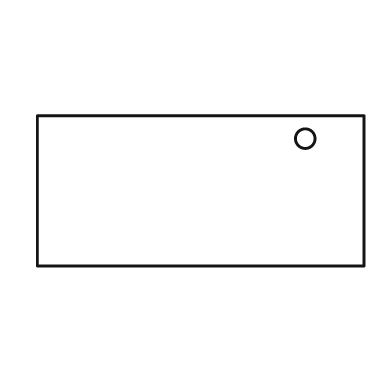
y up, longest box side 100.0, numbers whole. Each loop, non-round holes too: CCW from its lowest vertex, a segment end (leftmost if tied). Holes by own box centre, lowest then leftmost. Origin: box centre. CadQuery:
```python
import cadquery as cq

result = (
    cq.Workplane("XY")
    .moveTo(-50.0, -23.0)
    .lineTo(50.0, -23.0)
    .lineTo(50.0, 23.0)
    .lineTo(-50.0, 23.0)
    .close()
    .moveTo(32.0, 16.0)
    .circle(3.0)
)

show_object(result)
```